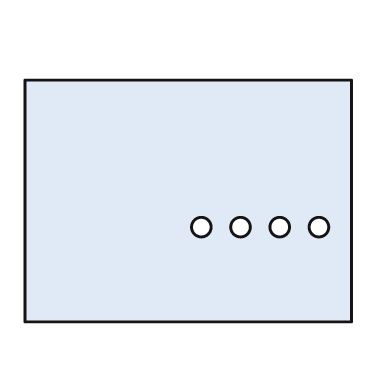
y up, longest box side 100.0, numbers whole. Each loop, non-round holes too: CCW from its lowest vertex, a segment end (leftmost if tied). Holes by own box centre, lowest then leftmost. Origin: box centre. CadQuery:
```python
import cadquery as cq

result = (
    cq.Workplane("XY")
    .moveTo(-50.0, -37.0)
    .lineTo(50.0, -37.0)
    .lineTo(50.0, 37.0)
    .lineTo(-50.0, 37.0)
    .close()
    .moveTo(4.0, -8.0)
    .circle(3.0)
    .moveTo(16.0, -8.0)
    .circle(3.0)
    .moveTo(28.0, -8.0)
    .circle(3.0)
    .moveTo(40.0, -8.0)
    .circle(3.0)
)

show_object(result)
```